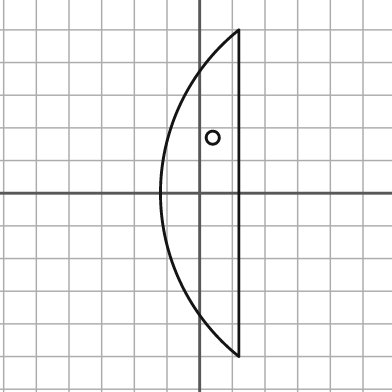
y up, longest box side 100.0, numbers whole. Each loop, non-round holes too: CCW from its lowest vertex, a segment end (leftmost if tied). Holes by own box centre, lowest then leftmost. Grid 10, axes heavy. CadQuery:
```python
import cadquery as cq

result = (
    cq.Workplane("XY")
    .moveTo(12.0, -50.0)
    .lineTo(12.0, 50.0)
    .threePointArc((-12.0, 0.0), (12.0, -50.0))
    .close()
    .moveTo(4.0, 17.0)
    .circle(2.0)
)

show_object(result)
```